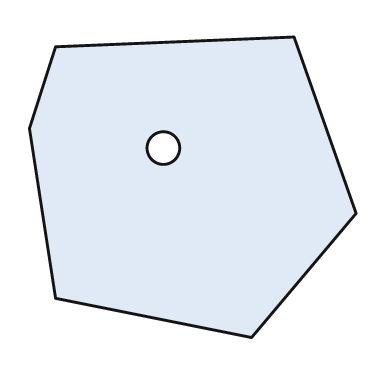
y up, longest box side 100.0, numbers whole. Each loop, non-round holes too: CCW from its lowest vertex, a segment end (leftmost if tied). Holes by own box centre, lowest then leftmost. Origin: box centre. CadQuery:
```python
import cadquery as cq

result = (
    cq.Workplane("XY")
    .moveTo(18.0, -46.0)
    .lineTo(50.0, -8.0)
    .lineTo(31.0, 46.0)
    .lineTo(-42.0, 43.0)
    .lineTo(-50.0, 18.0)
    .lineTo(-42.0, -34.0)
    .close()
    .moveTo(-9.0, 12.0)
    .circle(5.0)
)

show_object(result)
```